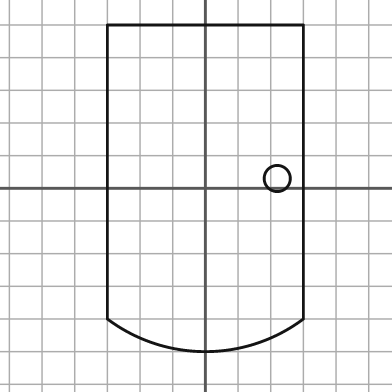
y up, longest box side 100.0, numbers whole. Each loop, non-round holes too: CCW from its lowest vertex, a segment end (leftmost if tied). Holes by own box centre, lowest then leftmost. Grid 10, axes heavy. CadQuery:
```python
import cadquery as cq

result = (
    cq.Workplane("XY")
    .moveTo(-30.0, -40.0)
    .threePointArc((0.0, -50.0), (30.0, -40.0))
    .lineTo(30.0, 50.0)
    .lineTo(-30.0, 50.0)
    .close()
    .moveTo(22.0, 3.0)
    .circle(4.0)
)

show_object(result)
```